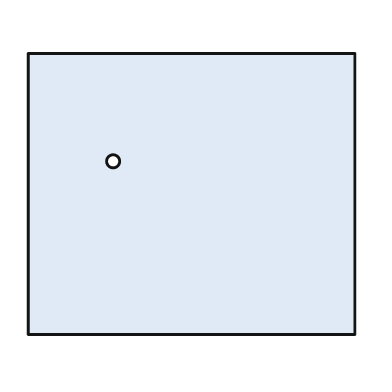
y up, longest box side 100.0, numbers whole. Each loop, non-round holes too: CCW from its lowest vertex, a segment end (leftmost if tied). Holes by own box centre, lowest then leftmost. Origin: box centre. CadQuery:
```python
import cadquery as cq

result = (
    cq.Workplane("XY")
    .moveTo(-50.0, -43.0)
    .lineTo(50.0, -43.0)
    .lineTo(50.0, 43.0)
    .lineTo(-50.0, 43.0)
    .close()
    .moveTo(-24.0, 10.0)
    .circle(2.0)
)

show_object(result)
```